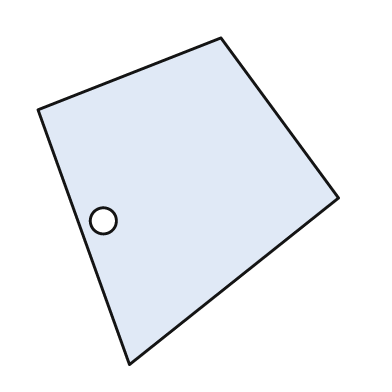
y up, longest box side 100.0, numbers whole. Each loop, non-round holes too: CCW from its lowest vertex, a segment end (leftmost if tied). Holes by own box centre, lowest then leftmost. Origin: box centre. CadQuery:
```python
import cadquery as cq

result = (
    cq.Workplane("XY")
    .moveTo(-18.0, -50.0)
    .lineTo(46.0, 1.0)
    .lineTo(10.0, 50.0)
    .lineTo(-46.0, 28.0)
    .close()
    .moveTo(-26.0, -6.0)
    .circle(4.0)
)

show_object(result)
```